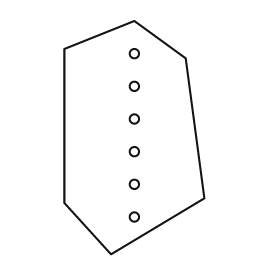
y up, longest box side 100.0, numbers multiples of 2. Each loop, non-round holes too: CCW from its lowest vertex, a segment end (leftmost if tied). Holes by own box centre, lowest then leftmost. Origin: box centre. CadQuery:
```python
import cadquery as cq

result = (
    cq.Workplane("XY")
    .moveTo(-10.0, -50.0)
    .lineTo(30.0, -26.0)
    .lineTo(22.0, 34.0)
    .lineTo(0.0, 50.0)
    .lineTo(-30.0, 38.0)
    .lineTo(-30.0, -28.0)
    .close()
    .moveTo(0.0, -34.0)
    .circle(2.0)
    .moveTo(0.0, -20.0)
    .circle(2.0)
    .moveTo(0.0, -6.0)
    .circle(2.0)
    .moveTo(0.0, 8.0)
    .circle(2.0)
    .moveTo(0.0, 22.0)
    .circle(2.0)
    .moveTo(0.0, 36.0)
    .circle(2.0)
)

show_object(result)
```